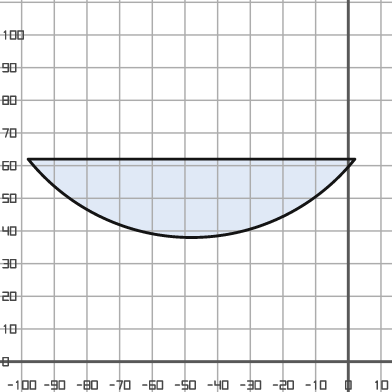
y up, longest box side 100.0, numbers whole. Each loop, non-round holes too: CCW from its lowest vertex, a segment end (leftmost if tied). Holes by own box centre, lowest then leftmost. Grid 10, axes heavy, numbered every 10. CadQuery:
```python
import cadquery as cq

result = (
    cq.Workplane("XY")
    .moveTo(-98.0, 62.0)
    .threePointArc((-48.0, 38.0), (2.0, 62.0))
    .close()
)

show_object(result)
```